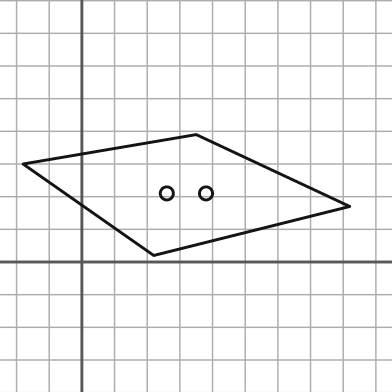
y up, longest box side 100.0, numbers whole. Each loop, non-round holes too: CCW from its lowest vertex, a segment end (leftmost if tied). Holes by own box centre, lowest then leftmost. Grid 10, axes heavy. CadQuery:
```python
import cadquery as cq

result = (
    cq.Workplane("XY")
    .moveTo(22.0, 2.0)
    .lineTo(82.0, 17.0)
    .lineTo(35.0, 39.0)
    .lineTo(-18.0, 30.0)
    .close()
    .moveTo(26.0, 21.0)
    .circle(2.0)
    .moveTo(38.0, 21.0)
    .circle(2.0)
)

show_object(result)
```